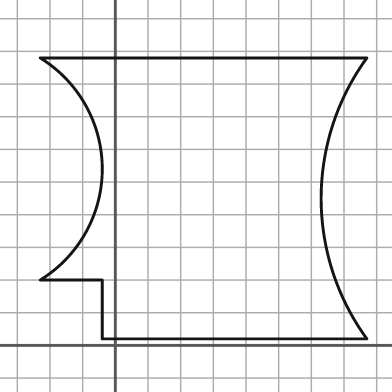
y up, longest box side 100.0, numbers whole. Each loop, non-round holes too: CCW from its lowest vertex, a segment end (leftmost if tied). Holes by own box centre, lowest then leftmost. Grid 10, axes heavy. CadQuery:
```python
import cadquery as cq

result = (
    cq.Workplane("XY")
    .moveTo(-4.0, 2.0)
    .lineTo(77.0, 2.0)
    .threePointArc((63.0, 45.0), (77.0, 88.0))
    .lineTo(-23.0, 88.0)
    .threePointArc((-4.0, 54.0), (-23.0, 20.0))
    .lineTo(-4.0, 20.0)
    .close()
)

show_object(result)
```